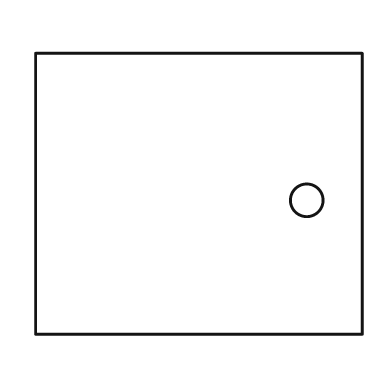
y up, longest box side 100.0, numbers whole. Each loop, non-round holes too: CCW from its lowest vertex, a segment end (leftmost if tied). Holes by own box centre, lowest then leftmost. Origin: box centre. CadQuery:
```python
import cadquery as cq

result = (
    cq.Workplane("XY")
    .moveTo(-50.0, -43.0)
    .lineTo(50.0, -43.0)
    .lineTo(50.0, 43.0)
    .lineTo(-50.0, 43.0)
    .close()
    .moveTo(33.0, -2.0)
    .circle(5.0)
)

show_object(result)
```